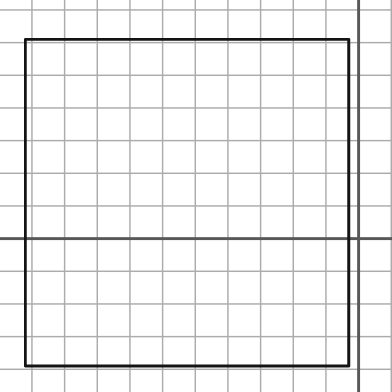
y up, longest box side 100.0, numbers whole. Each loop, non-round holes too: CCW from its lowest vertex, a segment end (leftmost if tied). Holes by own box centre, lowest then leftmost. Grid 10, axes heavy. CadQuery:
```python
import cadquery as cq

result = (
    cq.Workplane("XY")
    .moveTo(-102.0, -39.0)
    .lineTo(-3.0, -39.0)
    .lineTo(-3.0, 61.0)
    .lineTo(-102.0, 61.0)
    .close()
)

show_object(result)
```